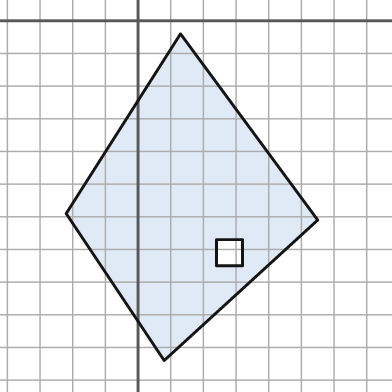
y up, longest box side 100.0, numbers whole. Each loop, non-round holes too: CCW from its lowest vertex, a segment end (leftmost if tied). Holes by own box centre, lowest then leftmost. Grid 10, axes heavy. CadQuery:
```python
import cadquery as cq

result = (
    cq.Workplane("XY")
    .moveTo(8.0, -104.0)
    .lineTo(55.0, -61.0)
    .lineTo(13.0, -4.0)
    .lineTo(-22.0, -59.0)
    .close()
    .moveTo(24.0, -75.0)
    .lineTo(32.0, -75.0)
    .lineTo(32.0, -67.0)
    .lineTo(24.0, -67.0)
    .close()
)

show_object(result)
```